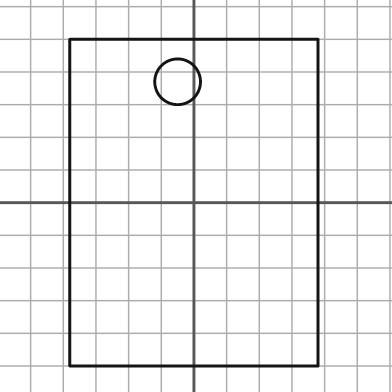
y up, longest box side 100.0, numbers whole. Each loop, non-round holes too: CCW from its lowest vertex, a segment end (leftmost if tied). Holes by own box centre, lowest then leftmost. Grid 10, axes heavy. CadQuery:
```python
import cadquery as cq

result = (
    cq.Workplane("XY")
    .moveTo(-38.0, -50.0)
    .lineTo(38.0, -50.0)
    .lineTo(38.0, 50.0)
    .lineTo(-38.0, 50.0)
    .close()
    .moveTo(-5.0, 37.0)
    .circle(7.0)
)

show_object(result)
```